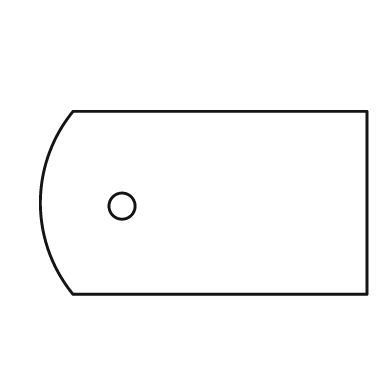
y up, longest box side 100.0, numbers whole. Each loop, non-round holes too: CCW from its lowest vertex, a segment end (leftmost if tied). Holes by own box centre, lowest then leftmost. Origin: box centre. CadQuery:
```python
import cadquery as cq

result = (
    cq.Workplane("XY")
    .moveTo(-40.0, -28.0)
    .lineTo(50.0, -28.0)
    .lineTo(50.0, 28.0)
    .lineTo(-40.0, 28.0)
    .threePointArc((-50.0, 0.0), (-40.0, -28.0))
    .close()
    .moveTo(-25.0, -1.0)
    .circle(4.0)
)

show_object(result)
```